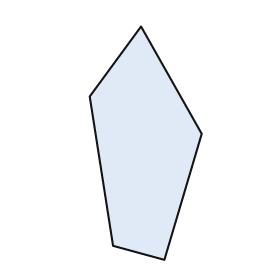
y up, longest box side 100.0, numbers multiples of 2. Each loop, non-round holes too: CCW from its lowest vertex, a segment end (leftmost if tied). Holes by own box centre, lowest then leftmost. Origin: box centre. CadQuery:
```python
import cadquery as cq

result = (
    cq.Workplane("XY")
    .moveTo(8.0, -50.0)
    .lineTo(24.0, 4.0)
    .lineTo(-2.0, 50.0)
    .lineTo(-24.0, 20.0)
    .lineTo(-14.0, -44.0)
    .close()
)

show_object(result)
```